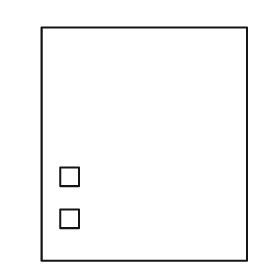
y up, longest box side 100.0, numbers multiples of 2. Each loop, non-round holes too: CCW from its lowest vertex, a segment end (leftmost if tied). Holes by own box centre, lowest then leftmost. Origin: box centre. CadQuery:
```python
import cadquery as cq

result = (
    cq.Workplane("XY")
    .moveTo(-44.0, -50.0)
    .lineTo(44.0, -50.0)
    .lineTo(44.0, 50.0)
    .lineTo(-44.0, 50.0)
    .close()
    .moveTo(-36.0, -36.0)
    .lineTo(-28.0, -36.0)
    .lineTo(-28.0, -28.0)
    .lineTo(-36.0, -28.0)
    .close()
    .moveTo(-36.0, -18.0)
    .lineTo(-28.0, -18.0)
    .lineTo(-28.0, -10.0)
    .lineTo(-36.0, -10.0)
    .close()
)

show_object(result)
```